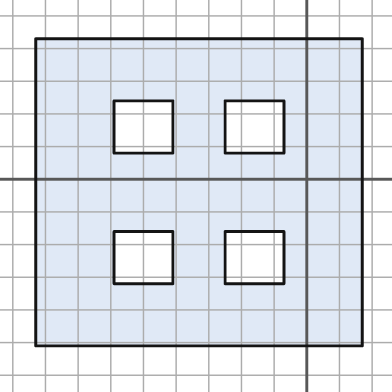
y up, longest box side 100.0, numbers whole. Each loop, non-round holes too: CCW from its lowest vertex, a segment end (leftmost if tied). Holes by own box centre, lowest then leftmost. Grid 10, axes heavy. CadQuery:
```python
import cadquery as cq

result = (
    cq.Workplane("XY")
    .moveTo(-83.0, -51.0)
    .lineTo(17.0, -51.0)
    .lineTo(17.0, 43.0)
    .lineTo(-83.0, 43.0)
    .close()
    .moveTo(-59.0, -32.0)
    .lineTo(-41.0, -32.0)
    .lineTo(-41.0, -16.0)
    .lineTo(-59.0, -16.0)
    .close()
    .moveTo(-25.0, -32.0)
    .lineTo(-7.0, -32.0)
    .lineTo(-7.0, -16.0)
    .lineTo(-25.0, -16.0)
    .close()
    .moveTo(-59.0, 8.0)
    .lineTo(-41.0, 8.0)
    .lineTo(-41.0, 24.0)
    .lineTo(-59.0, 24.0)
    .close()
    .moveTo(-25.0, 8.0)
    .lineTo(-7.0, 8.0)
    .lineTo(-7.0, 24.0)
    .lineTo(-25.0, 24.0)
    .close()
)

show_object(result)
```